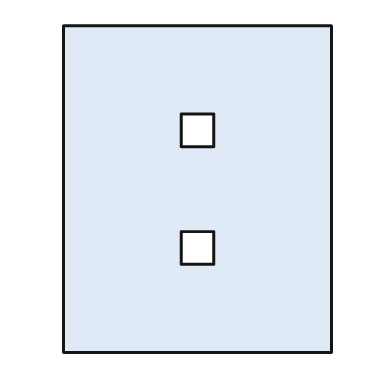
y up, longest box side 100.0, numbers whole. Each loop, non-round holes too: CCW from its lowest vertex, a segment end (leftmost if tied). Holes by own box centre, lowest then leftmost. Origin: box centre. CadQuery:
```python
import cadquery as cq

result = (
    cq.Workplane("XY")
    .moveTo(-41.0, -50.0)
    .lineTo(41.0, -50.0)
    .lineTo(41.0, 50.0)
    .lineTo(-41.0, 50.0)
    .close()
    .moveTo(-5.0, -23.0)
    .lineTo(5.0, -23.0)
    .lineTo(5.0, -13.0)
    .lineTo(-5.0, -13.0)
    .close()
    .moveTo(-5.0, 13.0)
    .lineTo(5.0, 13.0)
    .lineTo(5.0, 23.0)
    .lineTo(-5.0, 23.0)
    .close()
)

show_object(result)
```